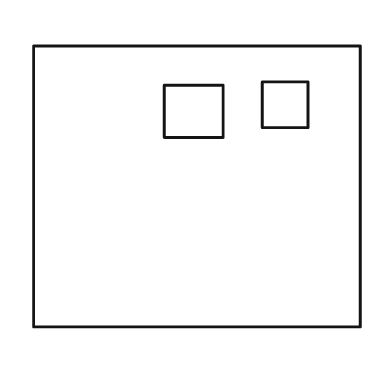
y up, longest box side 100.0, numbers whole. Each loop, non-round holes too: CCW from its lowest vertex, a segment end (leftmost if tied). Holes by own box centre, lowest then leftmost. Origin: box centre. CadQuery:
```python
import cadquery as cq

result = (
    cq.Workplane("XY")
    .moveTo(-50.0, -43.0)
    .lineTo(50.0, -43.0)
    .lineTo(50.0, 43.0)
    .lineTo(-50.0, 43.0)
    .close()
    .moveTo(-10.0, 15.0)
    .lineTo(8.0, 15.0)
    .lineTo(8.0, 31.0)
    .lineTo(-10.0, 31.0)
    .close()
    .moveTo(20.0, 18.0)
    .lineTo(34.0, 18.0)
    .lineTo(34.0, 32.0)
    .lineTo(20.0, 32.0)
    .close()
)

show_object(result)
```